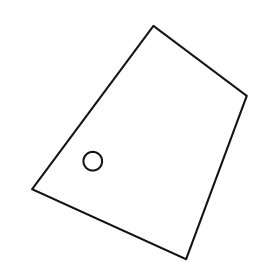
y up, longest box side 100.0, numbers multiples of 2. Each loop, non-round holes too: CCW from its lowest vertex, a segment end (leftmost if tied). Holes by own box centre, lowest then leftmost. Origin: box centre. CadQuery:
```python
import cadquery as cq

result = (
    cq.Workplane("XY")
    .moveTo(20.0, -50.0)
    .lineTo(46.0, 20.0)
    .lineTo(6.0, 50.0)
    .lineTo(-46.0, -20.0)
    .close()
    .moveTo(-20.0, -8.0)
    .circle(4.0)
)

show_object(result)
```